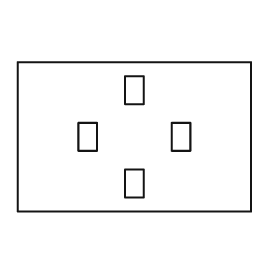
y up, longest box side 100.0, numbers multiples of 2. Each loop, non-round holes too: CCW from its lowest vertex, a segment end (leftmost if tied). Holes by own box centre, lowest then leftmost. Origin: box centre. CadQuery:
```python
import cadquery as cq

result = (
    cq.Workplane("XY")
    .moveTo(-50.0, -32.0)
    .lineTo(50.0, -32.0)
    .lineTo(50.0, 32.0)
    .lineTo(-50.0, 32.0)
    .close()
    .moveTo(-4.0, -26.0)
    .lineTo(4.0, -26.0)
    .lineTo(4.0, -14.0)
    .lineTo(-4.0, -14.0)
    .close()
    .moveTo(-24.0, -6.0)
    .lineTo(-16.0, -6.0)
    .lineTo(-16.0, 6.0)
    .lineTo(-24.0, 6.0)
    .close()
    .moveTo(16.0, -6.0)
    .lineTo(24.0, -6.0)
    .lineTo(24.0, 6.0)
    .lineTo(16.0, 6.0)
    .close()
    .moveTo(-4.0, 14.0)
    .lineTo(4.0, 14.0)
    .lineTo(4.0, 26.0)
    .lineTo(-4.0, 26.0)
    .close()
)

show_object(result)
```